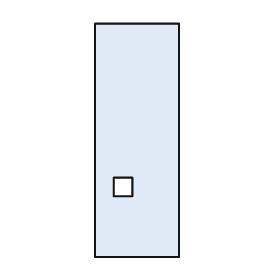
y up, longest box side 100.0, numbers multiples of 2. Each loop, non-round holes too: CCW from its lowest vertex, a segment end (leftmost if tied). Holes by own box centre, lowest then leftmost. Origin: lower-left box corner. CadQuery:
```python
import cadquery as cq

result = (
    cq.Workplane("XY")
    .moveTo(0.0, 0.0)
    .lineTo(36.0, 0.0)
    .lineTo(36.0, 100.0)
    .lineTo(0.0, 100.0)
    .close()
    .moveTo(8.0, 26.0)
    .lineTo(16.0, 26.0)
    .lineTo(16.0, 34.0)
    .lineTo(8.0, 34.0)
    .close()
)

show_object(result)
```